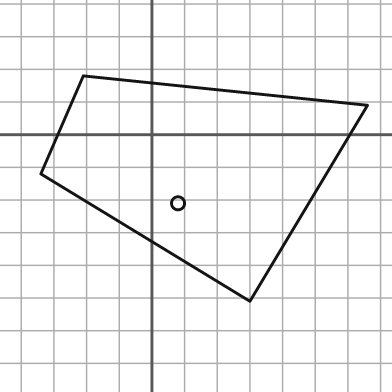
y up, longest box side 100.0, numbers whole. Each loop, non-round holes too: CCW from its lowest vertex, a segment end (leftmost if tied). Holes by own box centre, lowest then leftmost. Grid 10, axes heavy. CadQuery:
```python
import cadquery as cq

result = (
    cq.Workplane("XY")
    .moveTo(30.0, -51.0)
    .lineTo(66.0, 9.0)
    .lineTo(-21.0, 18.0)
    .lineTo(-34.0, -12.0)
    .close()
    .moveTo(8.0, -21.0)
    .circle(2.0)
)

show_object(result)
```